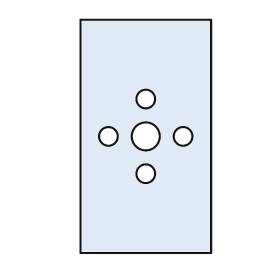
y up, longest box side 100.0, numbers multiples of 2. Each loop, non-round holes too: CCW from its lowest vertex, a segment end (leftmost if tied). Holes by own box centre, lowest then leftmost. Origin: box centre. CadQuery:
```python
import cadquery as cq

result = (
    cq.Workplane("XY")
    .moveTo(-28.0, -50.0)
    .lineTo(28.0, -50.0)
    .lineTo(28.0, 50.0)
    .lineTo(-28.0, 50.0)
    .close()
    .moveTo(0.0, -16.0)
    .circle(4.0)
    .moveTo(-16.0, 0.0)
    .circle(4.0)
    .moveTo(0.0, 0.0)
    .circle(6.0)
    .moveTo(16.0, 0.0)
    .circle(4.0)
    .moveTo(0.0, 16.0)
    .circle(4.0)
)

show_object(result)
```